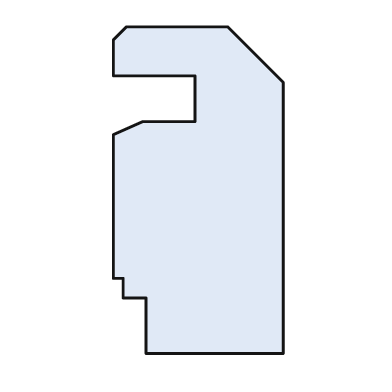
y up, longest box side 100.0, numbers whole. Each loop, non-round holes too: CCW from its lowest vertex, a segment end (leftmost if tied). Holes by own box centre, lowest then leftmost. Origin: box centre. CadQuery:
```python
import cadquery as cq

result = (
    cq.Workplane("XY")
    .moveTo(-16.0, -50.0)
    .lineTo(26.0, -50.0)
    .lineTo(26.0, 33.0)
    .lineTo(9.0, 50.0)
    .lineTo(-22.0, 50.0)
    .lineTo(-26.0, 46.0)
    .lineTo(-26.0, 35.0)
    .lineTo(-1.0, 35.0)
    .lineTo(-1.0, 21.0)
    .lineTo(-17.0, 21.0)
    .lineTo(-26.0, 17.0)
    .lineTo(-26.0, -27.0)
    .lineTo(-23.0, -27.0)
    .lineTo(-23.0, -33.0)
    .lineTo(-16.0, -33.0)
    .close()
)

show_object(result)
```